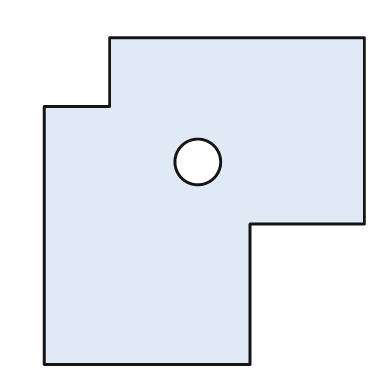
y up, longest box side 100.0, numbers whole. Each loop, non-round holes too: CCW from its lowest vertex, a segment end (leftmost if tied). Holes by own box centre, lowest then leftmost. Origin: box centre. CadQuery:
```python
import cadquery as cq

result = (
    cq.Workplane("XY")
    .moveTo(-49.0, -50.0)
    .lineTo(14.0, -50.0)
    .lineTo(14.0, -7.0)
    .lineTo(49.0, -7.0)
    .lineTo(49.0, 50.0)
    .lineTo(-29.0, 50.0)
    .lineTo(-29.0, 29.0)
    .lineTo(-49.0, 29.0)
    .close()
    .moveTo(-2.0, 12.0)
    .circle(7.0)
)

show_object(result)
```